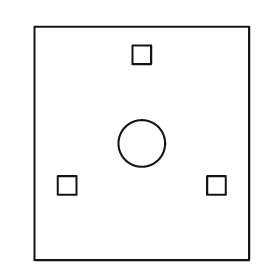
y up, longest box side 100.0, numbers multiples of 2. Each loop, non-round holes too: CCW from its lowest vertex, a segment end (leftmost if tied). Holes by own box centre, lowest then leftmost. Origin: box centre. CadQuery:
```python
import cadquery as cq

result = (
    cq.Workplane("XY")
    .moveTo(-46.0, -50.0)
    .lineTo(46.0, -50.0)
    .lineTo(46.0, 50.0)
    .lineTo(-46.0, 50.0)
    .close()
    .moveTo(-36.0, -22.0)
    .lineTo(-28.0, -22.0)
    .lineTo(-28.0, -14.0)
    .lineTo(-36.0, -14.0)
    .close()
    .moveTo(28.0, -22.0)
    .lineTo(36.0, -22.0)
    .lineTo(36.0, -14.0)
    .lineTo(28.0, -14.0)
    .close()
    .moveTo(0.0, 0.0)
    .circle(10.0)
    .moveTo(-4.0, 34.0)
    .lineTo(4.0, 34.0)
    .lineTo(4.0, 42.0)
    .lineTo(-4.0, 42.0)
    .close()
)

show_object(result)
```